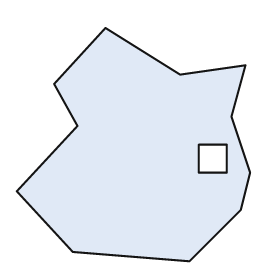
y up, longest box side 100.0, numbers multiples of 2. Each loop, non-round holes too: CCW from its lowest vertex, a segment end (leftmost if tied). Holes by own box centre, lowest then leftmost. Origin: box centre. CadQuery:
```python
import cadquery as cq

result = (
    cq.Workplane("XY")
    .moveTo(24.0, -50.0)
    .lineTo(46.0, -28.0)
    .lineTo(50.0, -12.0)
    .lineTo(42.0, 12.0)
    .lineTo(48.0, 34.0)
    .lineTo(20.0, 30.0)
    .lineTo(-12.0, 50.0)
    .lineTo(-34.0, 26.0)
    .lineTo(-24.0, 8.0)
    .lineTo(-50.0, -20.0)
    .lineTo(-26.0, -46.0)
    .close()
    .moveTo(28.0, -12.0)
    .lineTo(40.0, -12.0)
    .lineTo(40.0, 0.0)
    .lineTo(28.0, 0.0)
    .close()
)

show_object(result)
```